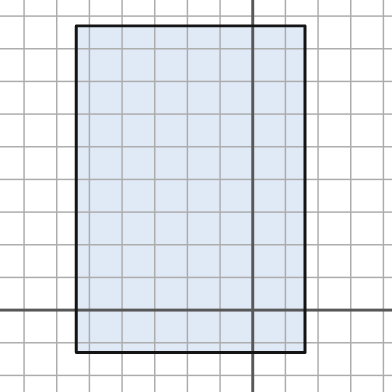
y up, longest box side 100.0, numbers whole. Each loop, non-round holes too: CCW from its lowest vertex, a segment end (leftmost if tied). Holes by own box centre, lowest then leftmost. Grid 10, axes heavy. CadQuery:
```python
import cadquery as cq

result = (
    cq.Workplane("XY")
    .moveTo(-54.0, -13.0)
    .lineTo(16.0, -13.0)
    .lineTo(16.0, 87.0)
    .lineTo(-54.0, 87.0)
    .close()
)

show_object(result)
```